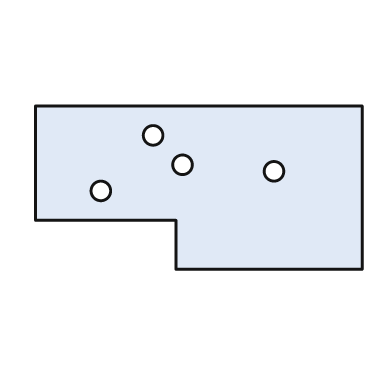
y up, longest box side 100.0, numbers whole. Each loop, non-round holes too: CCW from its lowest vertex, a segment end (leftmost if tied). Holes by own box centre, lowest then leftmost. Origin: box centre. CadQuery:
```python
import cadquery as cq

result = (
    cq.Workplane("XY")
    .moveTo(-7.0, -25.0)
    .lineTo(50.0, -25.0)
    .lineTo(50.0, 25.0)
    .lineTo(-50.0, 25.0)
    .lineTo(-50.0, -10.0)
    .lineTo(-7.0, -10.0)
    .close()
    .moveTo(-30.0, -1.0)
    .circle(3.0)
    .moveTo(23.0, 5.0)
    .circle(3.0)
    .moveTo(-5.0, 7.0)
    .circle(3.0)
    .moveTo(-14.0, 16.0)
    .circle(3.0)
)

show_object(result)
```